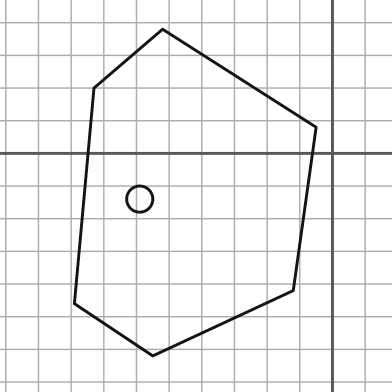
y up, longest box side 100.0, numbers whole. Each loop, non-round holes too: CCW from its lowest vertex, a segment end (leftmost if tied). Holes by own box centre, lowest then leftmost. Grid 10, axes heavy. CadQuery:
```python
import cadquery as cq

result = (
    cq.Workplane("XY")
    .moveTo(-55.0, -62.0)
    .lineTo(-12.0, -42.0)
    .lineTo(-5.0, 8.0)
    .lineTo(-52.0, 38.0)
    .lineTo(-73.0, 20.0)
    .lineTo(-79.0, -46.0)
    .close()
    .moveTo(-59.0, -14.0)
    .circle(4.0)
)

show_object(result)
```